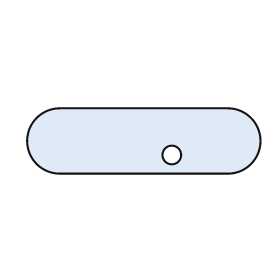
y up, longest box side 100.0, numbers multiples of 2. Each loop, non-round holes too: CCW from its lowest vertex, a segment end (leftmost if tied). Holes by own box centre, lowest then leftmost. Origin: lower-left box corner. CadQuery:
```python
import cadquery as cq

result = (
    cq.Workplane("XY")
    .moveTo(14.0, 0.0)
    .lineTo(86.0, 0.0)
    .threePointArc((100.0, 14.0), (86.0, 28.0))
    .lineTo(14.0, 28.0)
    .threePointArc((0.0, 14.0), (14.0, 0.0))
    .close()
    .moveTo(62.0, 8.0)
    .circle(4.0)
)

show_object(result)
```